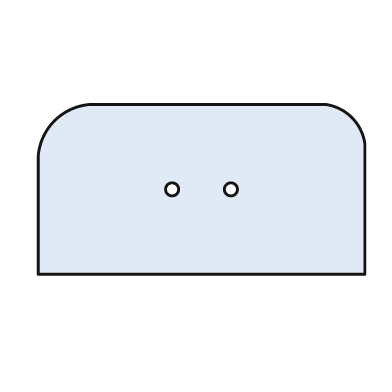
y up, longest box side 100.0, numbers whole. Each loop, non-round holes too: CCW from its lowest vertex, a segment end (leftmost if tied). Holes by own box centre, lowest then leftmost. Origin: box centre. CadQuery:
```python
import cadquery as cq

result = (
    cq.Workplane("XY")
    .moveTo(-50.0, -26.0)
    .lineTo(50.0, -26.0)
    .lineTo(50.0, 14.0)
    .threePointArc((46.0, 22.0), (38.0, 26.0))
    .lineTo(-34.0, 26.0)
    .threePointArc((-45.0, 21.0), (-50.0, 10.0))
    .close()
    .moveTo(-9.0, 0.0)
    .circle(2.0)
    .moveTo(9.0, 0.0)
    .circle(2.0)
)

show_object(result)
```